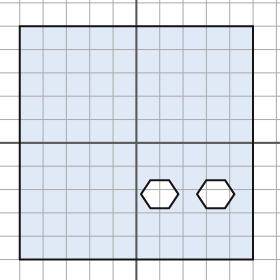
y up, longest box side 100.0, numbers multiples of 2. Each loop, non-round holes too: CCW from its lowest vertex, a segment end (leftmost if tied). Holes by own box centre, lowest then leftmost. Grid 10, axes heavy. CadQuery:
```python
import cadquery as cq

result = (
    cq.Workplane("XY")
    .moveTo(-50.0, -50.0)
    .lineTo(50.0, -50.0)
    .lineTo(50.0, 50.0)
    .lineTo(-50.0, 50.0)
    .close()
    .moveTo(6.0, -28.0)
    .lineTo(14.0, -28.0)
    .lineTo(18.0, -22.0)
    .lineTo(14.0, -16.0)
    .lineTo(6.0, -16.0)
    .lineTo(2.0, -22.0)
    .close()
    .moveTo(30.0, -28.0)
    .lineTo(38.0, -28.0)
    .lineTo(42.0, -22.0)
    .lineTo(38.0, -16.0)
    .lineTo(30.0, -16.0)
    .lineTo(26.0, -22.0)
    .close()
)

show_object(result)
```